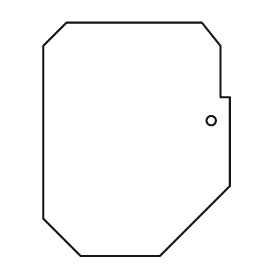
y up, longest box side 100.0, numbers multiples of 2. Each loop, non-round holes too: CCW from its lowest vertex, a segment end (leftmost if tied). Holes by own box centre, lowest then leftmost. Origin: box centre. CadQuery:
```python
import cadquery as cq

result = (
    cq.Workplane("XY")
    .moveTo(-24.0, -50.0)
    .lineTo(10.0, -50.0)
    .lineTo(40.0, -20.0)
    .lineTo(40.0, 18.0)
    .lineTo(36.0, 18.0)
    .lineTo(36.0, 40.0)
    .lineTo(28.0, 50.0)
    .lineTo(-30.0, 50.0)
    .lineTo(-40.0, 40.0)
    .lineTo(-40.0, -34.0)
    .close()
    .moveTo(32.0, 8.0)
    .circle(2.0)
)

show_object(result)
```